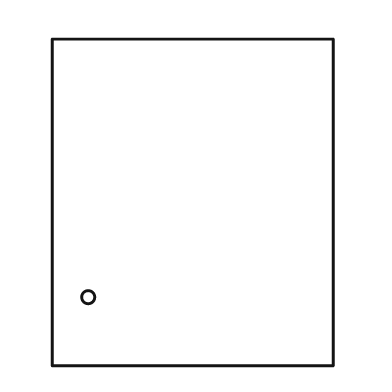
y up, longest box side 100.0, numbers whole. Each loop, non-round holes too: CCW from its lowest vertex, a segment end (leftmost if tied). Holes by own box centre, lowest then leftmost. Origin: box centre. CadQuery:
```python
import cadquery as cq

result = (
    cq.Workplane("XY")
    .moveTo(-43.0, -50.0)
    .lineTo(43.0, -50.0)
    .lineTo(43.0, 50.0)
    .lineTo(-43.0, 50.0)
    .close()
    .moveTo(-32.0, -29.0)
    .circle(2.0)
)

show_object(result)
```